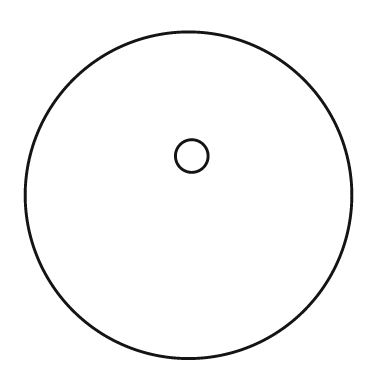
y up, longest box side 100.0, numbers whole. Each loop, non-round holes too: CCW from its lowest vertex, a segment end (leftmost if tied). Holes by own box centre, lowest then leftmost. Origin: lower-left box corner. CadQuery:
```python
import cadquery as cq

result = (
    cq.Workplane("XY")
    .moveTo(50.0, 50.0)
    .circle(50.0)
    .moveTo(51.0, 62.0)
    .circle(5.0)
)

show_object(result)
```